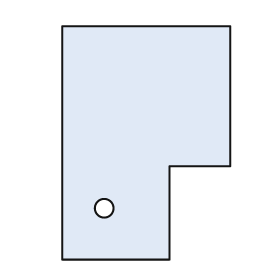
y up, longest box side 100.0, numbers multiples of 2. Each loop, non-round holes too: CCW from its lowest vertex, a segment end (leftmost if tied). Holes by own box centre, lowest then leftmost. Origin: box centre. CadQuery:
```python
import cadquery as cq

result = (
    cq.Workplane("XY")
    .moveTo(-36.0, -50.0)
    .lineTo(10.0, -50.0)
    .lineTo(10.0, -10.0)
    .lineTo(36.0, -10.0)
    .lineTo(36.0, 50.0)
    .lineTo(-36.0, 50.0)
    .close()
    .moveTo(-18.0, -28.0)
    .circle(4.0)
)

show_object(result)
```